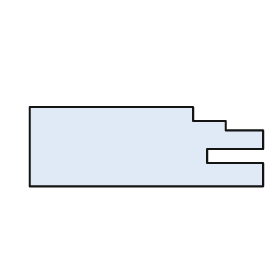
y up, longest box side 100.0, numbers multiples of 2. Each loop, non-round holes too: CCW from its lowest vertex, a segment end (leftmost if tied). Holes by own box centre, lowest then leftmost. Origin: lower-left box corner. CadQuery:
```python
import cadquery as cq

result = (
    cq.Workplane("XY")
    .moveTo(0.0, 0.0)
    .lineTo(100.0, 0.0)
    .lineTo(100.0, 10.0)
    .lineTo(76.0, 10.0)
    .lineTo(76.0, 16.0)
    .lineTo(100.0, 16.0)
    .lineTo(100.0, 24.0)
    .lineTo(84.0, 24.0)
    .lineTo(84.0, 28.0)
    .lineTo(70.0, 28.0)
    .lineTo(70.0, 34.0)
    .lineTo(0.0, 34.0)
    .close()
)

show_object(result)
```